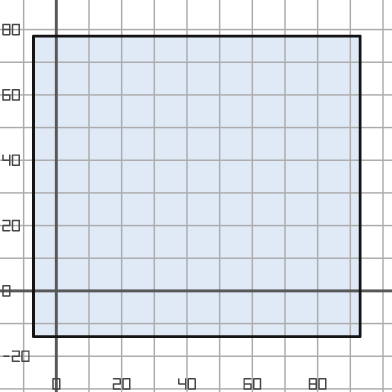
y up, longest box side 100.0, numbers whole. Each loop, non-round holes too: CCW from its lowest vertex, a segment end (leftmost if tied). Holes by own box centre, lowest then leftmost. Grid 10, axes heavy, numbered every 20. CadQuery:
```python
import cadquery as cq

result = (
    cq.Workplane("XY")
    .moveTo(-7.0, -14.0)
    .lineTo(93.0, -14.0)
    .lineTo(93.0, 78.0)
    .lineTo(-7.0, 78.0)
    .close()
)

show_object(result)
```